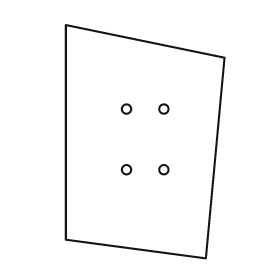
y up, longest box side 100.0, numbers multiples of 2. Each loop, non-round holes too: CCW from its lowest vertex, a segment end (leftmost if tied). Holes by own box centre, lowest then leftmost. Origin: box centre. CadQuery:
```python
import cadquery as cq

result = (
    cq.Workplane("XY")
    .moveTo(26.0, -50.0)
    .lineTo(34.0, 36.0)
    .lineTo(-34.0, 50.0)
    .lineTo(-34.0, -42.0)
    .close()
    .moveTo(-8.0, -12.0)
    .circle(2.0)
    .moveTo(8.0, -12.0)
    .circle(2.0)
    .moveTo(-8.0, 14.0)
    .circle(2.0)
    .moveTo(8.0, 14.0)
    .circle(2.0)
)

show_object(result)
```